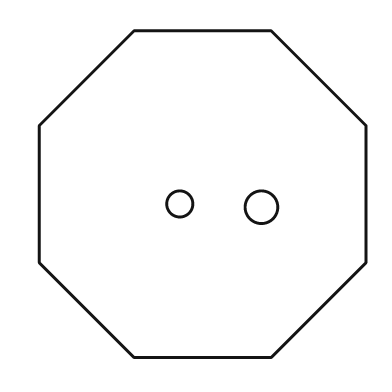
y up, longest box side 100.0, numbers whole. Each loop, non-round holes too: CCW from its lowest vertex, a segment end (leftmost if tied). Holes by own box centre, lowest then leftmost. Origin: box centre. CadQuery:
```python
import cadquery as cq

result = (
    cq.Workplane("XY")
    .moveTo(-21.0, -50.0)
    .lineTo(21.0, -50.0)
    .lineTo(50.0, -21.0)
    .lineTo(50.0, 21.0)
    .lineTo(21.0, 50.0)
    .lineTo(-21.0, 50.0)
    .lineTo(-50.0, 21.0)
    .lineTo(-50.0, -21.0)
    .close()
    .moveTo(18.0, -4.0)
    .circle(5.0)
    .moveTo(-7.0, -3.0)
    .circle(4.0)
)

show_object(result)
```